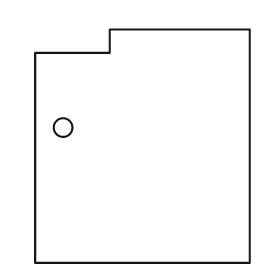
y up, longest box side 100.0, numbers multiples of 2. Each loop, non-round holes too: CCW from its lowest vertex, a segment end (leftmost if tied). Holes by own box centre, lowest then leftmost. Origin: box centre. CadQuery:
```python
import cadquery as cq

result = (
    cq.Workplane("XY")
    .moveTo(-46.0, -50.0)
    .lineTo(46.0, -50.0)
    .lineTo(46.0, 50.0)
    .lineTo(-14.0, 50.0)
    .lineTo(-14.0, 40.0)
    .lineTo(-46.0, 40.0)
    .close()
    .moveTo(-34.0, 8.0)
    .circle(4.0)
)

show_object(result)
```